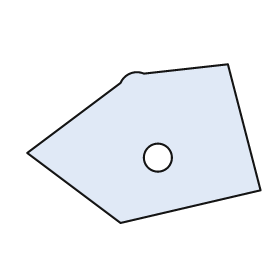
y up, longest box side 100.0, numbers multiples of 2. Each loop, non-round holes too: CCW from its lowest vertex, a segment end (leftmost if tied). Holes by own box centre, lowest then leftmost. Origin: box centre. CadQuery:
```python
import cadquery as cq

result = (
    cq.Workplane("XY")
    .moveTo(-10.0, -34.0)
    .lineTo(50.0, -20.0)
    .lineTo(36.0, 34.0)
    .lineTo(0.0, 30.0)
    .threePointArc((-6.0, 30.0), (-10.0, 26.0))
    .lineTo(-50.0, -4.0)
    .close()
    .moveTo(6.0, -6.0)
    .circle(6.0)
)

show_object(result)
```